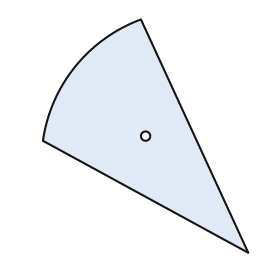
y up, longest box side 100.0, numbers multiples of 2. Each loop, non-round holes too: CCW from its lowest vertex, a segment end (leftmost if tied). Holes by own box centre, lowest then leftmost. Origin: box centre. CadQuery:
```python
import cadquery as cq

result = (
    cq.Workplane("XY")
    .moveTo(44.0, -50.0)
    .lineTo(-2.0, 50.0)
    .threePointArc((-30.0, 30.0), (-44.0, -2.0))
    .close()
    .moveTo(0.0, 0.0)
    .circle(2.0)
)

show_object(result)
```